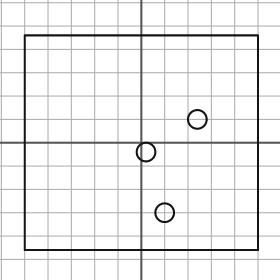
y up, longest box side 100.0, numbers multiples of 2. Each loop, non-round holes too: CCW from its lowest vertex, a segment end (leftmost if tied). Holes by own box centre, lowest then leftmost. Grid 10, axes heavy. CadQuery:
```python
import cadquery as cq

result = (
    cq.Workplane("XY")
    .moveTo(-50.0, -46.0)
    .lineTo(50.0, -46.0)
    .lineTo(50.0, 46.0)
    .lineTo(-50.0, 46.0)
    .close()
    .moveTo(10.0, -30.0)
    .circle(4.0)
    .moveTo(2.0, -4.0)
    .circle(4.0)
    .moveTo(24.0, 10.0)
    .circle(4.0)
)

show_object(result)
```